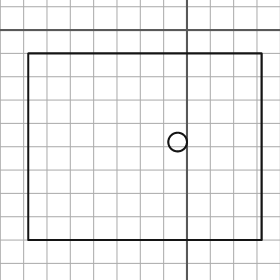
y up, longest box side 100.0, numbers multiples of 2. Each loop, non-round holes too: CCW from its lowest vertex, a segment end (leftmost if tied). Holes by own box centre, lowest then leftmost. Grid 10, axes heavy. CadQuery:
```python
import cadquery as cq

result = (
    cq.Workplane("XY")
    .moveTo(-68.0, -90.0)
    .lineTo(32.0, -90.0)
    .lineTo(32.0, -10.0)
    .lineTo(-68.0, -10.0)
    .close()
    .moveTo(-4.0, -48.0)
    .circle(4.0)
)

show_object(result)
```